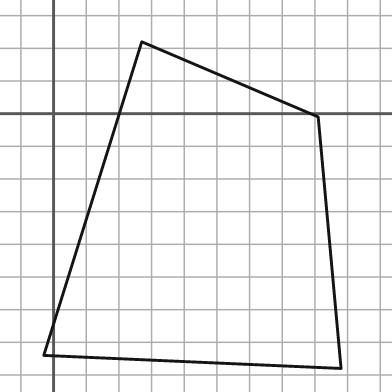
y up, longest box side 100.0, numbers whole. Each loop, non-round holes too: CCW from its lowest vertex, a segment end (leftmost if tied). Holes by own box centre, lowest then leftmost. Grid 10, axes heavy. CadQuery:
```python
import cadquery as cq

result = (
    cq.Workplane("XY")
    .moveTo(88.0, -78.0)
    .lineTo(81.0, -1.0)
    .lineTo(27.0, 22.0)
    .lineTo(-3.0, -74.0)
    .close()
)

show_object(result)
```